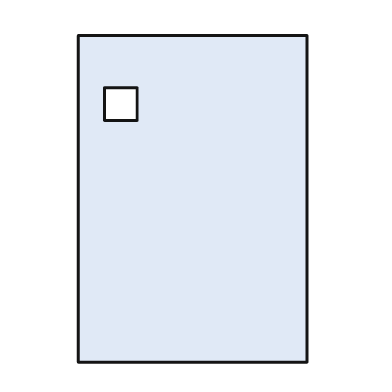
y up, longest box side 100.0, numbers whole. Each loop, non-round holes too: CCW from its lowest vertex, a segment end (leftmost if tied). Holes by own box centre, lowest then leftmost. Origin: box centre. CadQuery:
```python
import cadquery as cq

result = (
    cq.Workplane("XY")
    .moveTo(-35.0, -50.0)
    .lineTo(35.0, -50.0)
    .lineTo(35.0, 50.0)
    .lineTo(-35.0, 50.0)
    .close()
    .moveTo(-27.0, 24.0)
    .lineTo(-17.0, 24.0)
    .lineTo(-17.0, 34.0)
    .lineTo(-27.0, 34.0)
    .close()
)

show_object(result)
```